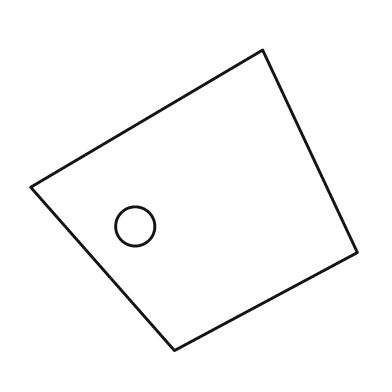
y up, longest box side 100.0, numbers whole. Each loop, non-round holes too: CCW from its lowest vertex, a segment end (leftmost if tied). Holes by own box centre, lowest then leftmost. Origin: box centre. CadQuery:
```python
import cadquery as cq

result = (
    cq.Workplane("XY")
    .moveTo(-6.0, -46.0)
    .lineTo(50.0, -16.0)
    .lineTo(21.0, 46.0)
    .lineTo(-50.0, 4.0)
    .close()
    .moveTo(-18.0, -8.0)
    .circle(6.0)
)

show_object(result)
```